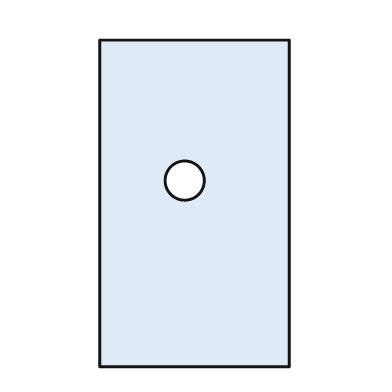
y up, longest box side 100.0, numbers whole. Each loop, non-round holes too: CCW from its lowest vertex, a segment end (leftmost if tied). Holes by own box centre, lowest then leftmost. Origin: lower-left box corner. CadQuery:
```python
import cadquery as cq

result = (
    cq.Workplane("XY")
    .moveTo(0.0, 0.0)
    .lineTo(58.0, 0.0)
    .lineTo(58.0, 100.0)
    .lineTo(0.0, 100.0)
    .close()
    .moveTo(26.0, 57.0)
    .circle(6.0)
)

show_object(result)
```